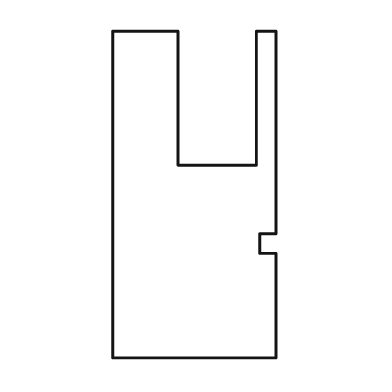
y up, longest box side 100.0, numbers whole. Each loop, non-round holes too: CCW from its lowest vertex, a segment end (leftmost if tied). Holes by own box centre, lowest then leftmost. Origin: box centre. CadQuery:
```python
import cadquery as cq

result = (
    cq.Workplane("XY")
    .moveTo(-25.0, -50.0)
    .lineTo(25.0, -50.0)
    .lineTo(25.0, -18.0)
    .lineTo(20.0, -18.0)
    .lineTo(20.0, -12.0)
    .lineTo(25.0, -12.0)
    .lineTo(25.0, 50.0)
    .lineTo(19.0, 50.0)
    .lineTo(19.0, 9.0)
    .lineTo(-5.0, 9.0)
    .lineTo(-5.0, 50.0)
    .lineTo(-25.0, 50.0)
    .close()
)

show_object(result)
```